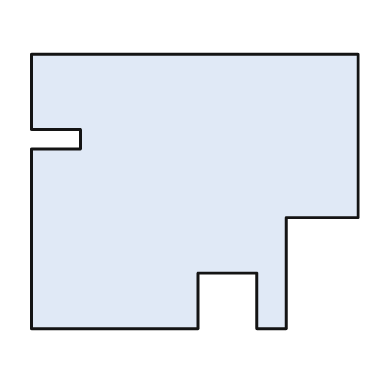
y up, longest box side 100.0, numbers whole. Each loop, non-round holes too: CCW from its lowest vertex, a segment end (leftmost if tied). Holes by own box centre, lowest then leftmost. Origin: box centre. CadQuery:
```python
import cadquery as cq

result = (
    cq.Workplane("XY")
    .moveTo(-50.0, -42.0)
    .lineTo(1.0, -42.0)
    .lineTo(1.0, -25.0)
    .lineTo(19.0, -25.0)
    .lineTo(19.0, -42.0)
    .lineTo(28.0, -42.0)
    .lineTo(28.0, -8.0)
    .lineTo(50.0, -8.0)
    .lineTo(50.0, 42.0)
    .lineTo(-50.0, 42.0)
    .lineTo(-50.0, 19.0)
    .lineTo(-35.0, 19.0)
    .lineTo(-35.0, 13.0)
    .lineTo(-50.0, 13.0)
    .close()
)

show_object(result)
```